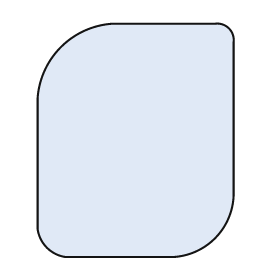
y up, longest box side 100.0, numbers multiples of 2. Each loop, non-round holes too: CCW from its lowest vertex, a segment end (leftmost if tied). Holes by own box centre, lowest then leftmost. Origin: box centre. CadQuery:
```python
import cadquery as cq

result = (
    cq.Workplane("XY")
    .moveTo(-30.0, -50.0)
    .lineTo(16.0, -50.0)
    .threePointArc((34.0, -42.0), (42.0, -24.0))
    .lineTo(42.0, 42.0)
    .threePointArc((40.0, 48.0), (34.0, 50.0))
    .lineTo(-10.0, 50.0)
    .threePointArc((-32.0, 40.0), (-42.0, 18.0))
    .lineTo(-42.0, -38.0)
    .threePointArc((-38.0, -46.0), (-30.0, -50.0))
    .close()
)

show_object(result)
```